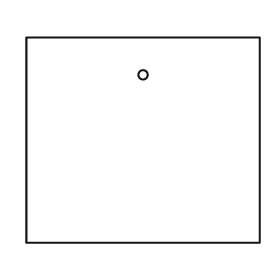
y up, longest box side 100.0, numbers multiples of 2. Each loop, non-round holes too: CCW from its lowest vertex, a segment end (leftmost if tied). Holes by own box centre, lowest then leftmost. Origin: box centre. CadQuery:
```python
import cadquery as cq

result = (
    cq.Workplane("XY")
    .moveTo(-50.0, -44.0)
    .lineTo(50.0, -44.0)
    .lineTo(50.0, 44.0)
    .lineTo(-50.0, 44.0)
    .close()
    .moveTo(0.0, 28.0)
    .circle(2.0)
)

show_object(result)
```